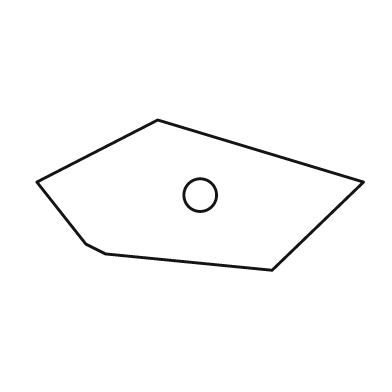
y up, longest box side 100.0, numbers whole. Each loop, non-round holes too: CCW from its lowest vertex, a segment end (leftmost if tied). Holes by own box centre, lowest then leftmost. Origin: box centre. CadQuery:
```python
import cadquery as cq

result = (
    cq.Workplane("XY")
    .moveTo(22.0, -23.0)
    .lineTo(50.0, 4.0)
    .lineTo(-13.0, 23.0)
    .lineTo(-50.0, 4.0)
    .lineTo(-35.0, -15.0)
    .lineTo(-29.0, -18.0)
    .close()
    .moveTo(0.0, 0.0)
    .circle(5.0)
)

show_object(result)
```